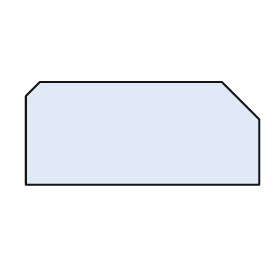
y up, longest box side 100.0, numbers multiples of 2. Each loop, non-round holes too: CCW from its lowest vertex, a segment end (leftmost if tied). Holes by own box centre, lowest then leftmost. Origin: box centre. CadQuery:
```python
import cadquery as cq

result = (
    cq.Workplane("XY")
    .moveTo(-50.0, -22.0)
    .lineTo(50.0, -22.0)
    .lineTo(50.0, 6.0)
    .lineTo(34.0, 22.0)
    .lineTo(-44.0, 22.0)
    .lineTo(-50.0, 16.0)
    .close()
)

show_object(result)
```